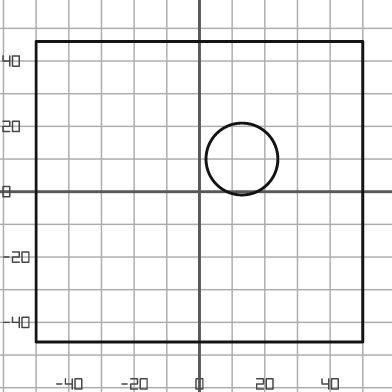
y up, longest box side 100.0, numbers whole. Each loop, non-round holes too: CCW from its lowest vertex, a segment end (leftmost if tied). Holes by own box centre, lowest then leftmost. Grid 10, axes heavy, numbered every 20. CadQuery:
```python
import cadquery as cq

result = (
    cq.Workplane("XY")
    .moveTo(-50.0, -46.0)
    .lineTo(50.0, -46.0)
    .lineTo(50.0, 46.0)
    .lineTo(-50.0, 46.0)
    .close()
    .moveTo(13.0, 10.0)
    .circle(11.0)
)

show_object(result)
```